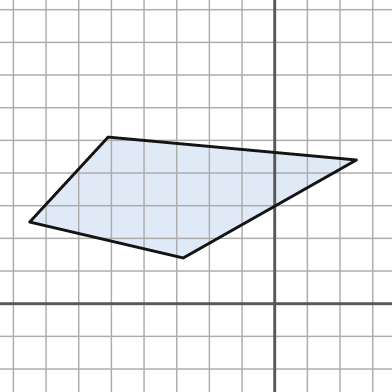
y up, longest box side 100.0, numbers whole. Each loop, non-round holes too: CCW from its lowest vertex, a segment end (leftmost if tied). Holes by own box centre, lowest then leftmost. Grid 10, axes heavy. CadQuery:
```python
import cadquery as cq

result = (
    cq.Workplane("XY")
    .moveTo(-28.0, 14.0)
    .lineTo(25.0, 44.0)
    .lineTo(-51.0, 51.0)
    .lineTo(-75.0, 25.0)
    .close()
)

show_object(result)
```